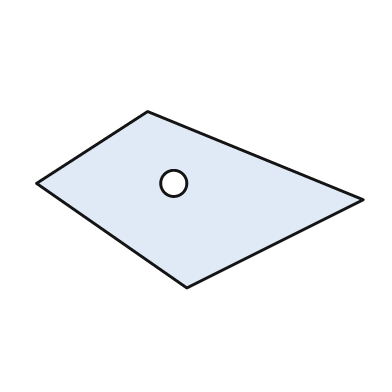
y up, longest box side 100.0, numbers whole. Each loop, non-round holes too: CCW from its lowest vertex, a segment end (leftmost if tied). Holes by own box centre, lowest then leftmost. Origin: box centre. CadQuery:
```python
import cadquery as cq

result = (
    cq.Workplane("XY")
    .moveTo(-4.0, -27.0)
    .lineTo(50.0, 0.0)
    .lineTo(-16.0, 27.0)
    .lineTo(-50.0, 5.0)
    .close()
    .moveTo(-8.0, 5.0)
    .circle(4.0)
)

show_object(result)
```